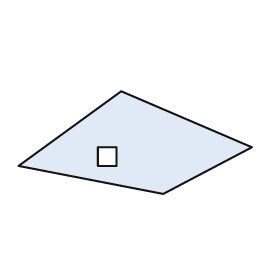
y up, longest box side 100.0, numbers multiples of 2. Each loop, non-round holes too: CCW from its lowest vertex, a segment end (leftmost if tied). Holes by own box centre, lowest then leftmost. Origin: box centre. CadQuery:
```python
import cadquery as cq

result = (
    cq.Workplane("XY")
    .moveTo(12.0, -22.0)
    .lineTo(50.0, -2.0)
    .lineTo(-6.0, 22.0)
    .lineTo(-50.0, -10.0)
    .close()
    .moveTo(-16.0, -10.0)
    .lineTo(-8.0, -10.0)
    .lineTo(-8.0, -2.0)
    .lineTo(-16.0, -2.0)
    .close()
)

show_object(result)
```